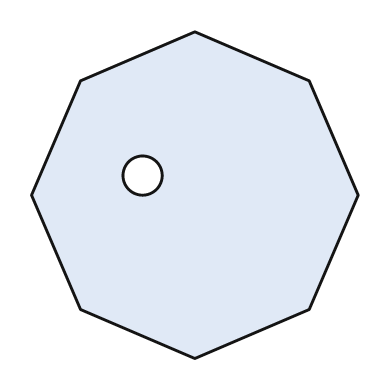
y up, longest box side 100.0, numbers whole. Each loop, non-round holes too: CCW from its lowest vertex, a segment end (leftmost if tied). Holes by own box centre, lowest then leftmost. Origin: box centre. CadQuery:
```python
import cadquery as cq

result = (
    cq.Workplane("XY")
    .moveTo(0.0, -50.0)
    .lineTo(35.0, -35.0)
    .lineTo(50.0, 0.0)
    .lineTo(35.0, 35.0)
    .lineTo(0.0, 50.0)
    .lineTo(-35.0, 35.0)
    .lineTo(-50.0, 0.0)
    .lineTo(-35.0, -35.0)
    .close()
    .moveTo(-16.0, 6.0)
    .circle(6.0)
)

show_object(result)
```